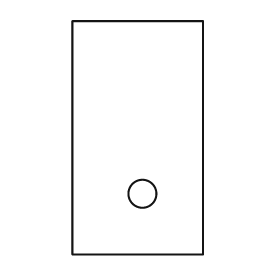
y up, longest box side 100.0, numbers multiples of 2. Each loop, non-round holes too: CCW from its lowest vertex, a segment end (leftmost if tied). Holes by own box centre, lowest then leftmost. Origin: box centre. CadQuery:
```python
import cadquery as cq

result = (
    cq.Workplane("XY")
    .moveTo(-28.0, -50.0)
    .lineTo(28.0, -50.0)
    .lineTo(28.0, 50.0)
    .lineTo(-28.0, 50.0)
    .close()
    .moveTo(2.0, -24.0)
    .circle(6.0)
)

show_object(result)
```